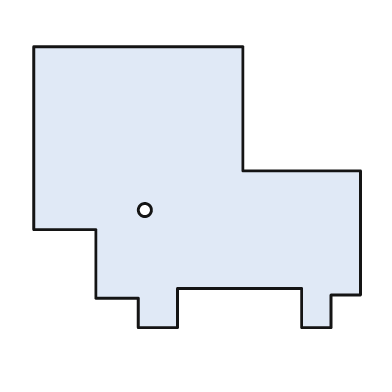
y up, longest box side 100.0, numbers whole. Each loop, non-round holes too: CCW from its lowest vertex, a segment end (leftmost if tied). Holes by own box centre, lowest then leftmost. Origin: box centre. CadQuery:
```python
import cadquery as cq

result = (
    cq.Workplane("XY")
    .moveTo(-18.0, -43.0)
    .lineTo(-6.0, -43.0)
    .lineTo(-6.0, -31.0)
    .lineTo(32.0, -31.0)
    .lineTo(32.0, -43.0)
    .lineTo(41.0, -43.0)
    .lineTo(41.0, -33.0)
    .lineTo(50.0, -33.0)
    .lineTo(50.0, 5.0)
    .lineTo(14.0, 5.0)
    .lineTo(14.0, 43.0)
    .lineTo(-50.0, 43.0)
    .lineTo(-50.0, -13.0)
    .lineTo(-31.0, -13.0)
    .lineTo(-31.0, -34.0)
    .lineTo(-18.0, -34.0)
    .close()
    .moveTo(-16.0, -7.0)
    .circle(2.0)
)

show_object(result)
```